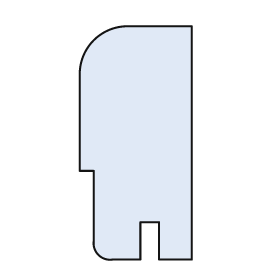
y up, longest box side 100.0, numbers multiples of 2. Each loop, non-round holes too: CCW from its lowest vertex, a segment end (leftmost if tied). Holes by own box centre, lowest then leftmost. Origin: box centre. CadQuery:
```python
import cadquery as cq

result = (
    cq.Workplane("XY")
    .moveTo(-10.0, -50.0)
    .lineTo(2.0, -50.0)
    .lineTo(2.0, -34.0)
    .lineTo(10.0, -34.0)
    .lineTo(10.0, -50.0)
    .lineTo(24.0, -50.0)
    .lineTo(24.0, 50.0)
    .lineTo(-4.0, 50.0)
    .threePointArc((-18.0, 44.0), (-24.0, 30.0))
    .lineTo(-24.0, -12.0)
    .lineTo(-18.0, -12.0)
    .lineTo(-18.0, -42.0)
    .threePointArc((-16.0, -48.0), (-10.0, -50.0))
    .close()
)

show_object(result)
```